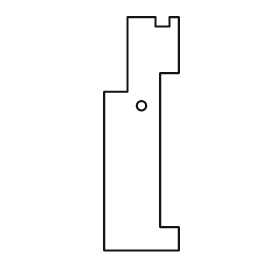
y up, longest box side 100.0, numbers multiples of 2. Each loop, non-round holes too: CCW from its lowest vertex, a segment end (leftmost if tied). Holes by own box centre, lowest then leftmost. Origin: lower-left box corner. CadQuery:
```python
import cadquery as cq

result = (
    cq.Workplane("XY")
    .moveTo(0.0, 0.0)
    .lineTo(32.0, 0.0)
    .lineTo(32.0, 10.0)
    .lineTo(24.0, 10.0)
    .lineTo(24.0, 76.0)
    .lineTo(32.0, 76.0)
    .lineTo(32.0, 100.0)
    .lineTo(28.0, 100.0)
    .lineTo(28.0, 96.0)
    .lineTo(22.0, 96.0)
    .lineTo(22.0, 100.0)
    .lineTo(10.0, 100.0)
    .lineTo(10.0, 68.0)
    .lineTo(0.0, 68.0)
    .close()
    .moveTo(16.0, 62.0)
    .circle(2.0)
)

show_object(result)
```